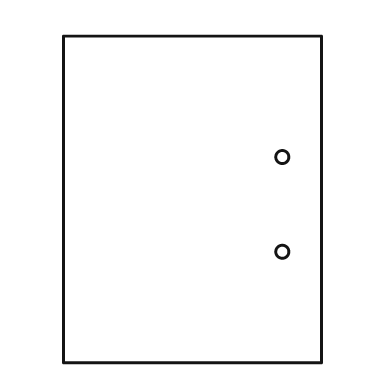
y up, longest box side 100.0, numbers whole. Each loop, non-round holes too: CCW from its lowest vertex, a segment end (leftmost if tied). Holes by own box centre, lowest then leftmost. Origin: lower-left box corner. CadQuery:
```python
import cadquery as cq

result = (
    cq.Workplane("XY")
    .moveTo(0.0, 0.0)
    .lineTo(79.0, 0.0)
    .lineTo(79.0, 100.0)
    .lineTo(0.0, 100.0)
    .close()
    .moveTo(67.0, 34.0)
    .circle(2.0)
    .moveTo(67.0, 63.0)
    .circle(2.0)
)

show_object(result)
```